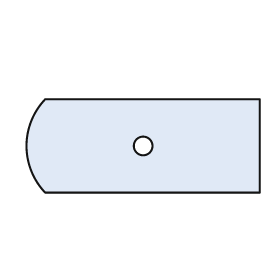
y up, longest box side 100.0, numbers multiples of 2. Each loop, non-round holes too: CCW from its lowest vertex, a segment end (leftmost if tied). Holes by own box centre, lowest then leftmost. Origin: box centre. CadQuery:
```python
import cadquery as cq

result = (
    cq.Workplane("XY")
    .moveTo(-42.0, -20.0)
    .lineTo(50.0, -20.0)
    .lineTo(50.0, 20.0)
    .lineTo(-42.0, 20.0)
    .threePointArc((-50.0, 0.0), (-42.0, -20.0))
    .close()
    .moveTo(0.0, 0.0)
    .circle(4.0)
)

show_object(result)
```